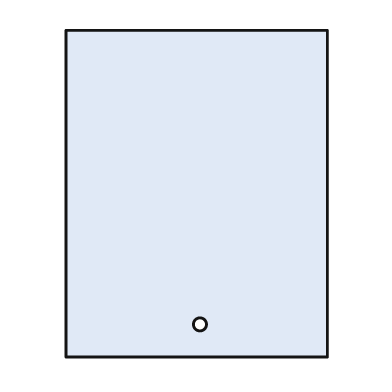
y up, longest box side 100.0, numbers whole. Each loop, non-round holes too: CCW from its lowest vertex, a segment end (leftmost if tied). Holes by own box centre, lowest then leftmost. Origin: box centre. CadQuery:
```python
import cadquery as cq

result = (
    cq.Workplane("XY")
    .moveTo(-40.0, -50.0)
    .lineTo(40.0, -50.0)
    .lineTo(40.0, 50.0)
    .lineTo(-40.0, 50.0)
    .close()
    .moveTo(1.0, -40.0)
    .circle(2.0)
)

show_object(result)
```